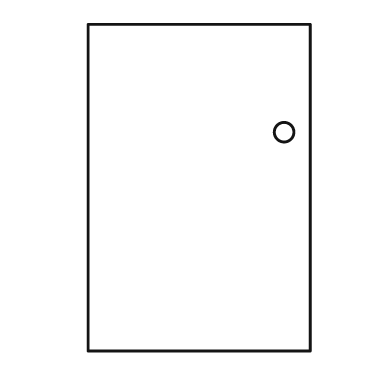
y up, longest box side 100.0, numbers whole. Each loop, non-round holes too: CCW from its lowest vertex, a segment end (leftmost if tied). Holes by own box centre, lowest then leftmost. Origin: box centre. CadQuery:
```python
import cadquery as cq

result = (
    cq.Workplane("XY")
    .moveTo(-34.0, -50.0)
    .lineTo(34.0, -50.0)
    .lineTo(34.0, 50.0)
    .lineTo(-34.0, 50.0)
    .close()
    .moveTo(26.0, 17.0)
    .circle(3.0)
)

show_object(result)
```